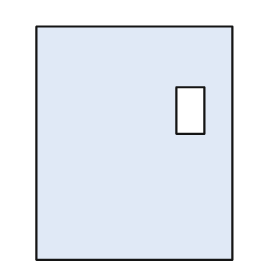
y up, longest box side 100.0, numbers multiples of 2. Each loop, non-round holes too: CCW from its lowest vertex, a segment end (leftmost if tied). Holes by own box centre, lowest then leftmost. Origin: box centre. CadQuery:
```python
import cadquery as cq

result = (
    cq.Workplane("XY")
    .moveTo(-42.0, -50.0)
    .lineTo(42.0, -50.0)
    .lineTo(42.0, 50.0)
    .lineTo(-42.0, 50.0)
    .close()
    .moveTo(18.0, 4.0)
    .lineTo(30.0, 4.0)
    .lineTo(30.0, 24.0)
    .lineTo(18.0, 24.0)
    .close()
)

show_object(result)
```